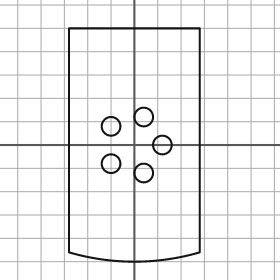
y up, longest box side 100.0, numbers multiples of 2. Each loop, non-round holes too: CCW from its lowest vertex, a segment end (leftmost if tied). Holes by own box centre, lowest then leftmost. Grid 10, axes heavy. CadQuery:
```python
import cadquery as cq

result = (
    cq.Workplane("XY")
    .moveTo(-28.0, -46.0)
    .threePointArc((0.0, -50.0), (28.0, -46.0))
    .lineTo(28.0, 50.0)
    .lineTo(-28.0, 50.0)
    .close()
    .moveTo(4.0, -12.0)
    .circle(4.0)
    .moveTo(-10.0, -8.0)
    .circle(4.0)
    .moveTo(12.0, 0.0)
    .circle(4.0)
    .moveTo(-10.0, 8.0)
    .circle(4.0)
    .moveTo(4.0, 12.0)
    .circle(4.0)
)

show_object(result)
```